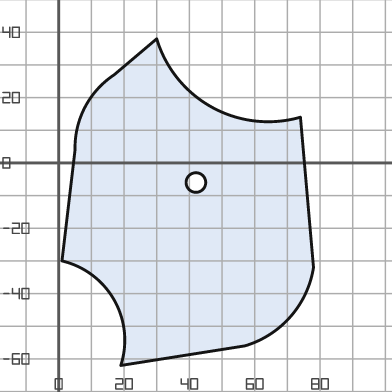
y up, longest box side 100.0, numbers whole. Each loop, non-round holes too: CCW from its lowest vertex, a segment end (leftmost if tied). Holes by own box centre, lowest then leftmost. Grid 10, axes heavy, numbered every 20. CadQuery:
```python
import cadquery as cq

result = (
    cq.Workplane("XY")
    .moveTo(19.0, -62.0)
    .lineTo(57.0, -56.0)
    .threePointArc((71.0, -47.0), (78.0, -32.0))
    .lineTo(74.0, 14.0)
    .threePointArc((47.0, 17.0), (30.0, 38.0))
    .lineTo(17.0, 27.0)
    .threePointArc((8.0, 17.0), (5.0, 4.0))
    .lineTo(1.0, -30.0)
    .threePointArc((17.0, -42.0), (19.0, -62.0))
    .close()
    .moveTo(42.0, -6.0)
    .circle(3.0)
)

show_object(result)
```